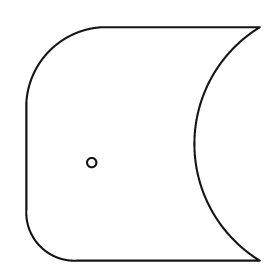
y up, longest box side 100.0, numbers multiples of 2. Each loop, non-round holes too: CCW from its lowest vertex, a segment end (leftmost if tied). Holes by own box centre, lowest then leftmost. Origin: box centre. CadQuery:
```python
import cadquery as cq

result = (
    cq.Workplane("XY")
    .moveTo(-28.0, -50.0)
    .lineTo(50.0, -50.0)
    .threePointArc((22.0, 0.0), (50.0, 50.0))
    .lineTo(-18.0, 50.0)
    .threePointArc((-40.0, 40.0), (-50.0, 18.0))
    .lineTo(-50.0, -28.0)
    .threePointArc((-44.0, -44.0), (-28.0, -50.0))
    .close()
    .moveTo(-22.0, -8.0)
    .circle(2.0)
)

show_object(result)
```